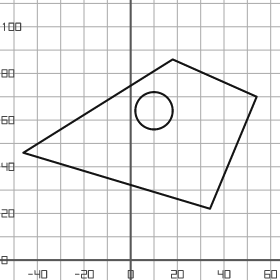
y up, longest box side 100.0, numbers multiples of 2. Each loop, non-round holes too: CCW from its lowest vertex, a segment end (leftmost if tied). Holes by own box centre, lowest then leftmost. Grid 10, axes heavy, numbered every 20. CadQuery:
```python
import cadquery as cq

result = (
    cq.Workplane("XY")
    .moveTo(34.0, 22.0)
    .lineTo(54.0, 70.0)
    .lineTo(18.0, 86.0)
    .lineTo(-46.0, 46.0)
    .close()
    .moveTo(10.0, 64.0)
    .circle(8.0)
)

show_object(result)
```